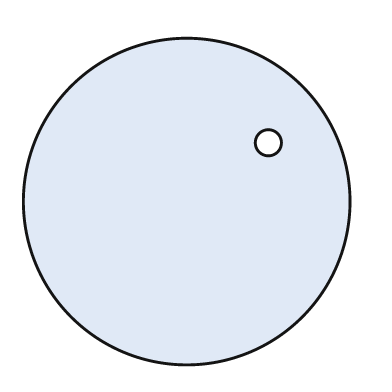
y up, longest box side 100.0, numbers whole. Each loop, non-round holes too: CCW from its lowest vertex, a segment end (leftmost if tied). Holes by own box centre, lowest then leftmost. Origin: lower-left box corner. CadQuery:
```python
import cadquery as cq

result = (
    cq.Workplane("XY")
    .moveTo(50.0, 50.0)
    .circle(50.0)
    .moveTo(75.0, 68.0)
    .circle(4.0)
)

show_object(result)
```